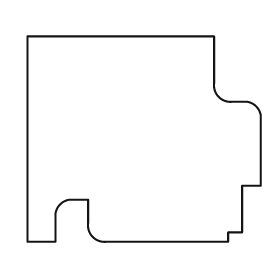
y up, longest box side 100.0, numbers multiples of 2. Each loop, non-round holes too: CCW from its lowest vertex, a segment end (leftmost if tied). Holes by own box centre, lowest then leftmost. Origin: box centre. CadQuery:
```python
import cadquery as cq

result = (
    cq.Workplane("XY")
    .moveTo(-50.0, -44.0)
    .lineTo(-38.0, -44.0)
    .lineTo(-38.0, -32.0)
    .threePointArc((-36.0, -28.0), (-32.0, -26.0))
    .lineTo(-24.0, -26.0)
    .lineTo(-24.0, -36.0)
    .threePointArc((-22.0, -42.0), (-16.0, -44.0))
    .lineTo(36.0, -44.0)
    .lineTo(36.0, -40.0)
    .lineTo(42.0, -40.0)
    .lineTo(42.0, -20.0)
    .lineTo(50.0, -20.0)
    .lineTo(50.0, 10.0)
    .threePointArc((48.0, 14.0), (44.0, 16.0))
    .lineTo(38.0, 16.0)
    .threePointArc((32.0, 18.0), (30.0, 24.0))
    .lineTo(30.0, 44.0)
    .lineTo(-50.0, 44.0)
    .close()
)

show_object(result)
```